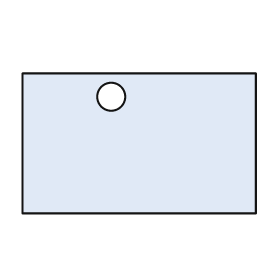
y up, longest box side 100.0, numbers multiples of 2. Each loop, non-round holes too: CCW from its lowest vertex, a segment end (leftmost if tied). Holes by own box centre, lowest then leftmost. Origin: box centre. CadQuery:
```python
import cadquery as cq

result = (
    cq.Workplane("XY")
    .moveTo(-50.0, -30.0)
    .lineTo(50.0, -30.0)
    .lineTo(50.0, 30.0)
    .lineTo(-50.0, 30.0)
    .close()
    .moveTo(-12.0, 20.0)
    .circle(6.0)
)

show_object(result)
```